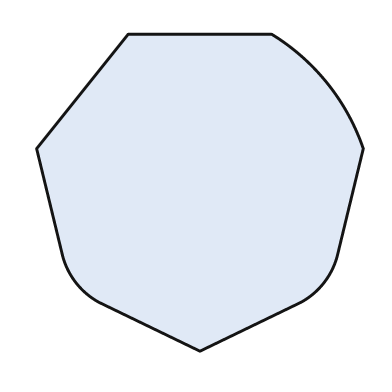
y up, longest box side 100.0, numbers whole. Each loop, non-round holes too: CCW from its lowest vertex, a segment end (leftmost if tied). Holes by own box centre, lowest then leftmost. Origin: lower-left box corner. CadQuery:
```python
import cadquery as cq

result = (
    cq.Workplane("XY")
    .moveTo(50.0, 0.0)
    .lineTo(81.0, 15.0)
    .threePointArc((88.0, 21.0), (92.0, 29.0))
    .lineTo(100.0, 62.0)
    .threePointArc((89.0, 82.0), (72.0, 97.0))
    .lineTo(28.0, 97.0)
    .lineTo(0.0, 62.0)
    .lineTo(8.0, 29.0)
    .threePointArc((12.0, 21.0), (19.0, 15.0))
    .close()
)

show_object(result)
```